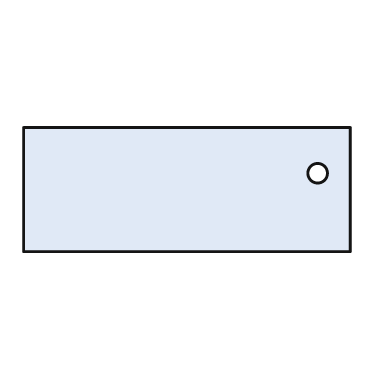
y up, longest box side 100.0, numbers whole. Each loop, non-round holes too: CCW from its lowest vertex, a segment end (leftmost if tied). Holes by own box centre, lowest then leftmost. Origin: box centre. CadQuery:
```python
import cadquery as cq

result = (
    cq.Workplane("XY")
    .moveTo(-50.0, -19.0)
    .lineTo(50.0, -19.0)
    .lineTo(50.0, 19.0)
    .lineTo(-50.0, 19.0)
    .close()
    .moveTo(40.0, 5.0)
    .circle(3.0)
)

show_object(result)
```